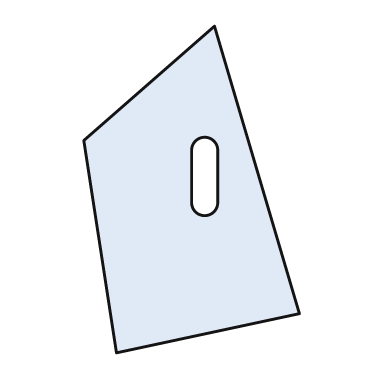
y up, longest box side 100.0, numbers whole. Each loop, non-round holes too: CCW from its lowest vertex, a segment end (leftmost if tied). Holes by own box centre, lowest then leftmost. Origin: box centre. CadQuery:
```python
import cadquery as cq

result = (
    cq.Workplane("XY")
    .moveTo(-23.0, -50.0)
    .lineTo(33.0, -38.0)
    .lineTo(7.0, 50.0)
    .lineTo(-33.0, 15.0)
    .close()
    .moveTo(0.0, -4.0)
    .threePointArc((4.0, -8.0), (8.0, -4.0))
    .lineTo(8.0, 12.0)
    .threePointArc((4.0, 16.0), (0.0, 12.0))
    .close()
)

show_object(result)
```